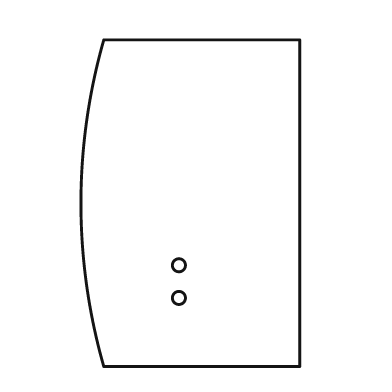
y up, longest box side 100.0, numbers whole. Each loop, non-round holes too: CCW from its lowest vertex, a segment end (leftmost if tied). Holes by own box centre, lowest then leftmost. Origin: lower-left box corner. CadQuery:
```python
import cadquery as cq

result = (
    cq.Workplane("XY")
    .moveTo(7.0, 0.0)
    .lineTo(67.0, 0.0)
    .lineTo(67.0, 100.0)
    .lineTo(7.0, 100.0)
    .threePointArc((0.0, 50.0), (7.0, 0.0))
    .close()
    .moveTo(30.0, 21.0)
    .circle(2.0)
    .moveTo(30.0, 31.0)
    .circle(2.0)
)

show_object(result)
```